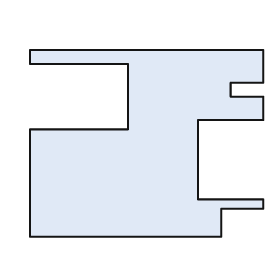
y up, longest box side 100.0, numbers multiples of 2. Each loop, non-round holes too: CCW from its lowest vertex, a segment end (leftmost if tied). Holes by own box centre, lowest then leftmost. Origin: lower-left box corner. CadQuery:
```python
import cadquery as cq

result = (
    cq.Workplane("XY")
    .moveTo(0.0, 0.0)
    .lineTo(82.0, 0.0)
    .lineTo(82.0, 12.0)
    .lineTo(100.0, 12.0)
    .lineTo(100.0, 16.0)
    .lineTo(72.0, 16.0)
    .lineTo(72.0, 50.0)
    .lineTo(100.0, 50.0)
    .lineTo(100.0, 60.0)
    .lineTo(86.0, 60.0)
    .lineTo(86.0, 66.0)
    .lineTo(100.0, 66.0)
    .lineTo(100.0, 80.0)
    .lineTo(0.0, 80.0)
    .lineTo(0.0, 74.0)
    .lineTo(42.0, 74.0)
    .lineTo(42.0, 46.0)
    .lineTo(0.0, 46.0)
    .close()
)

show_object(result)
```